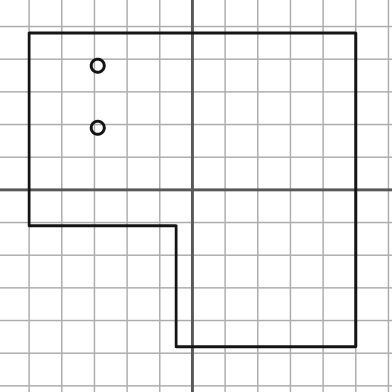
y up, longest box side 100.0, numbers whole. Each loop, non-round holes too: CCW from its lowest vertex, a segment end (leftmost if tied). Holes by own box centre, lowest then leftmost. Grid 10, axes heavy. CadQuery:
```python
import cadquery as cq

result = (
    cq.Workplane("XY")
    .moveTo(-5.0, -48.0)
    .lineTo(50.0, -48.0)
    .lineTo(50.0, 48.0)
    .lineTo(-50.0, 48.0)
    .lineTo(-50.0, -11.0)
    .lineTo(-5.0, -11.0)
    .close()
    .moveTo(-29.0, 19.0)
    .circle(2.0)
    .moveTo(-29.0, 38.0)
    .circle(2.0)
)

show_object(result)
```